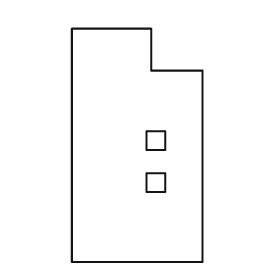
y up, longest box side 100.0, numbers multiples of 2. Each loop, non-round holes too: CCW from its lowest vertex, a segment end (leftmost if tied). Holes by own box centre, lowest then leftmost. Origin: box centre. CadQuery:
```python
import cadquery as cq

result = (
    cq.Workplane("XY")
    .moveTo(-28.0, -50.0)
    .lineTo(28.0, -50.0)
    .lineTo(28.0, 32.0)
    .lineTo(6.0, 32.0)
    .lineTo(6.0, 50.0)
    .lineTo(-28.0, 50.0)
    .close()
    .moveTo(4.0, -20.0)
    .lineTo(12.0, -20.0)
    .lineTo(12.0, -12.0)
    .lineTo(4.0, -12.0)
    .close()
    .moveTo(4.0, -2.0)
    .lineTo(12.0, -2.0)
    .lineTo(12.0, 6.0)
    .lineTo(4.0, 6.0)
    .close()
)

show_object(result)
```